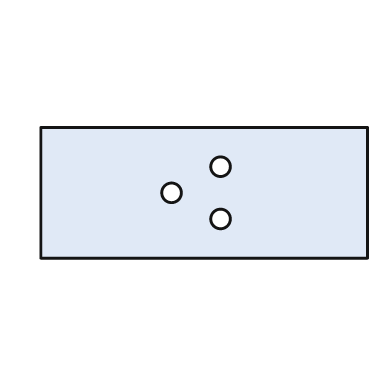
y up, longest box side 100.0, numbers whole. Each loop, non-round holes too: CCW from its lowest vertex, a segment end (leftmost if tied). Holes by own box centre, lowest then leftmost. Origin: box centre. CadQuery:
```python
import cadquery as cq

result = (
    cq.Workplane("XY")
    .moveTo(-50.0, -20.0)
    .lineTo(50.0, -20.0)
    .lineTo(50.0, 20.0)
    .lineTo(-50.0, 20.0)
    .close()
    .moveTo(5.0, -8.0)
    .circle(3.0)
    .moveTo(-10.0, 0.0)
    .circle(3.0)
    .moveTo(5.0, 8.0)
    .circle(3.0)
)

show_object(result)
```